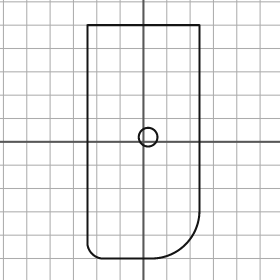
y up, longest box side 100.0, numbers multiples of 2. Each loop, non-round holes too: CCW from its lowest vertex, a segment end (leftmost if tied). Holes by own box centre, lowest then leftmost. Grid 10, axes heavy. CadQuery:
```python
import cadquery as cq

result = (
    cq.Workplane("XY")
    .moveTo(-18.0, -50.0)
    .lineTo(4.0, -50.0)
    .threePointArc((18.0, -44.0), (24.0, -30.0))
    .lineTo(24.0, 50.0)
    .lineTo(-24.0, 50.0)
    .lineTo(-24.0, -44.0)
    .threePointArc((-22.0, -48.0), (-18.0, -50.0))
    .close()
    .moveTo(2.0, 2.0)
    .circle(4.0)
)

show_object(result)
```